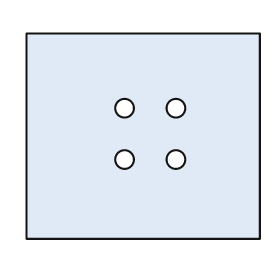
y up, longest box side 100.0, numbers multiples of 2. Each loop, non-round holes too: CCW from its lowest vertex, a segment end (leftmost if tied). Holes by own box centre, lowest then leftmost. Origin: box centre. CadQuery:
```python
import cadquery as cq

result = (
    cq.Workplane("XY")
    .moveTo(-50.0, -44.0)
    .lineTo(50.0, -44.0)
    .lineTo(50.0, 44.0)
    .lineTo(-50.0, 44.0)
    .close()
    .moveTo(-8.0, -10.0)
    .circle(4.0)
    .moveTo(14.0, -10.0)
    .circle(4.0)
    .moveTo(-8.0, 12.0)
    .circle(4.0)
    .moveTo(14.0, 12.0)
    .circle(4.0)
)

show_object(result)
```